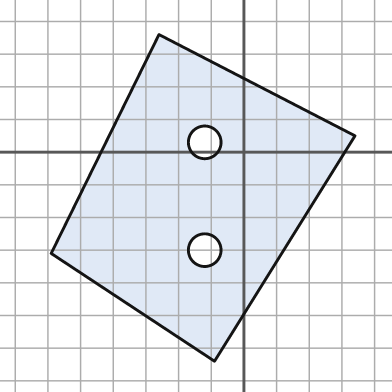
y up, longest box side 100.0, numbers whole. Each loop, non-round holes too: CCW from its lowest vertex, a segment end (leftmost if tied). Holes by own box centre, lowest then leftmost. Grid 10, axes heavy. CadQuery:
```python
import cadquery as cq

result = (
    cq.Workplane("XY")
    .moveTo(-9.0, -64.0)
    .lineTo(34.0, 5.0)
    .lineTo(-26.0, 36.0)
    .lineTo(-59.0, -31.0)
    .close()
    .moveTo(-12.0, -30.0)
    .circle(5.0)
    .moveTo(-12.0, 3.0)
    .circle(5.0)
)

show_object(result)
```